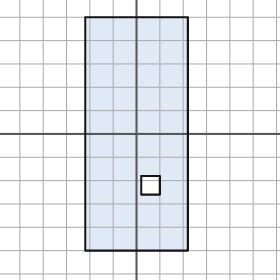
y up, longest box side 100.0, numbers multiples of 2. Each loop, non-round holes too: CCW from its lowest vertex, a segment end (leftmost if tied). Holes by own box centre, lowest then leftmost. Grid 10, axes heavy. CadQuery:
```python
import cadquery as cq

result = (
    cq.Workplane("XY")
    .moveTo(-22.0, -50.0)
    .lineTo(22.0, -50.0)
    .lineTo(22.0, 50.0)
    .lineTo(-22.0, 50.0)
    .close()
    .moveTo(2.0, -26.0)
    .lineTo(10.0, -26.0)
    .lineTo(10.0, -18.0)
    .lineTo(2.0, -18.0)
    .close()
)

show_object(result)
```